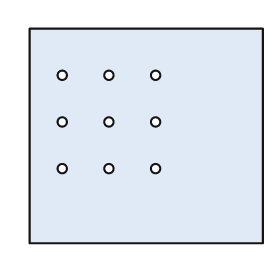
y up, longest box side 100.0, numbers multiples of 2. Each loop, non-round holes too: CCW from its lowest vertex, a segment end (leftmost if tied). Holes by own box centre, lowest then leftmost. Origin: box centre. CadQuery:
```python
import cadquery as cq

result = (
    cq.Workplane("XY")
    .moveTo(-50.0, -46.0)
    .lineTo(50.0, -46.0)
    .lineTo(50.0, 46.0)
    .lineTo(-50.0, 46.0)
    .close()
    .moveTo(-36.0, -14.0)
    .circle(2.0)
    .moveTo(-16.0, -14.0)
    .circle(2.0)
    .moveTo(4.0, -14.0)
    .circle(2.0)
    .moveTo(-36.0, 6.0)
    .circle(2.0)
    .moveTo(-16.0, 6.0)
    .circle(2.0)
    .moveTo(4.0, 6.0)
    .circle(2.0)
    .moveTo(-36.0, 26.0)
    .circle(2.0)
    .moveTo(-16.0, 26.0)
    .circle(2.0)
    .moveTo(4.0, 26.0)
    .circle(2.0)
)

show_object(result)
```